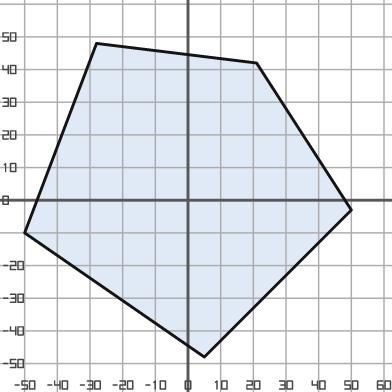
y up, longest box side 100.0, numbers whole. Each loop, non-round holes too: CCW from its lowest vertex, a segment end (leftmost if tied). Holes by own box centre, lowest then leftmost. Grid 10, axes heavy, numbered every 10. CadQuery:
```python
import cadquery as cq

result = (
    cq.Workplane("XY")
    .moveTo(5.0, -48.0)
    .lineTo(50.0, -3.0)
    .lineTo(21.0, 42.0)
    .lineTo(-28.0, 48.0)
    .lineTo(-50.0, -10.0)
    .close()
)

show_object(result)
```